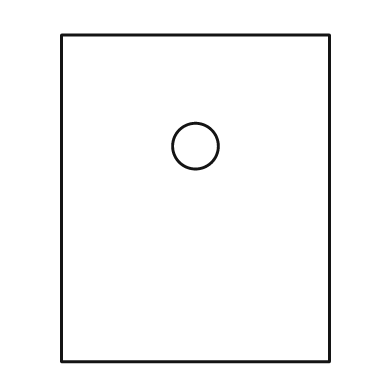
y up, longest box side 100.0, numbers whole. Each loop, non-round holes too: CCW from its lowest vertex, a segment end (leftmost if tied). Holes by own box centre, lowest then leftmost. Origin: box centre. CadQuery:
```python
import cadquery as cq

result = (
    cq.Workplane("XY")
    .moveTo(-41.0, -50.0)
    .lineTo(41.0, -50.0)
    .lineTo(41.0, 50.0)
    .lineTo(-41.0, 50.0)
    .close()
    .moveTo(0.0, 16.0)
    .circle(7.0)
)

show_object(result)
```